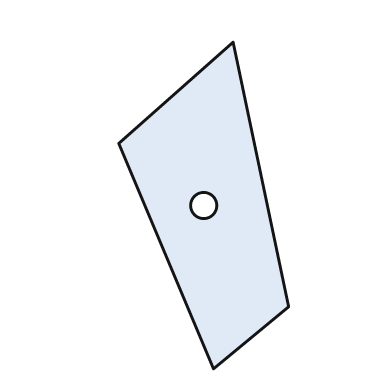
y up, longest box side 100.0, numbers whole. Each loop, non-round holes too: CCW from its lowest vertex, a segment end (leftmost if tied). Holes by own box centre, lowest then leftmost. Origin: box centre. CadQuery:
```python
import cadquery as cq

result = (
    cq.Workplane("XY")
    .moveTo(3.0, -50.0)
    .lineTo(26.0, -31.0)
    .lineTo(9.0, 50.0)
    .lineTo(-26.0, 19.0)
    .close()
    .moveTo(0.0, 0.0)
    .circle(4.0)
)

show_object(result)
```